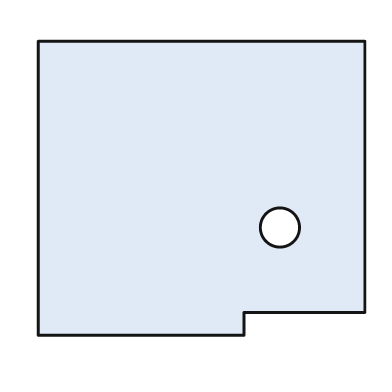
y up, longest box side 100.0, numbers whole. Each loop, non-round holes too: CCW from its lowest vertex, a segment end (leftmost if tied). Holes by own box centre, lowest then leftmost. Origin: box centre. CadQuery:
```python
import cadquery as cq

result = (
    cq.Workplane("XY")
    .moveTo(-50.0, -45.0)
    .lineTo(13.0, -45.0)
    .lineTo(13.0, -38.0)
    .lineTo(50.0, -38.0)
    .lineTo(50.0, 45.0)
    .lineTo(-50.0, 45.0)
    .close()
    .moveTo(24.0, -12.0)
    .circle(6.0)
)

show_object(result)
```